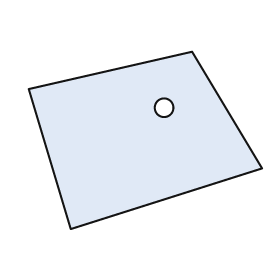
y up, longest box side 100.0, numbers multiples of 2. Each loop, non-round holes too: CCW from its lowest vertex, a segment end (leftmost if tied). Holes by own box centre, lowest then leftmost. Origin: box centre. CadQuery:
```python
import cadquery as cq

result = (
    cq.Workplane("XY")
    .moveTo(-32.0, -38.0)
    .lineTo(50.0, -12.0)
    .lineTo(20.0, 38.0)
    .lineTo(-50.0, 22.0)
    .close()
    .moveTo(8.0, 14.0)
    .circle(4.0)
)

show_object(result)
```